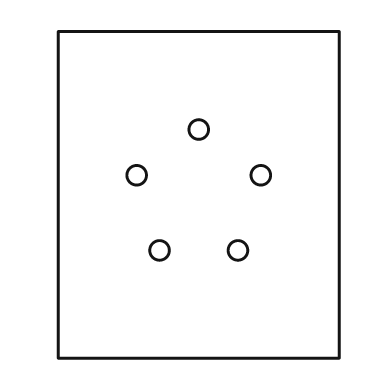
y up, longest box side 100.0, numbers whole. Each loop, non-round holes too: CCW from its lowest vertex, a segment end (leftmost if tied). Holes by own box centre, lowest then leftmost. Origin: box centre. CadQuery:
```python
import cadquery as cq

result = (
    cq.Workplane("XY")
    .moveTo(-43.0, -50.0)
    .lineTo(43.0, -50.0)
    .lineTo(43.0, 50.0)
    .lineTo(-43.0, 50.0)
    .close()
    .moveTo(-12.0, -17.0)
    .circle(3.0)
    .moveTo(12.0, -17.0)
    .circle(3.0)
    .moveTo(-19.0, 6.0)
    .circle(3.0)
    .moveTo(19.0, 6.0)
    .circle(3.0)
    .moveTo(0.0, 20.0)
    .circle(3.0)
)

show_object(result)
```